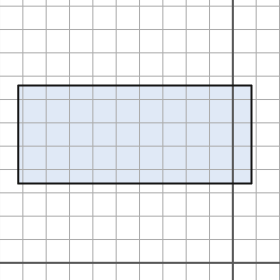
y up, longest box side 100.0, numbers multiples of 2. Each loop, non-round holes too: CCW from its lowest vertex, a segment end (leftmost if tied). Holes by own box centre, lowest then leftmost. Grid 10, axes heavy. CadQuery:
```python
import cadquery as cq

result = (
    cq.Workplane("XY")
    .moveTo(-92.0, 34.0)
    .lineTo(8.0, 34.0)
    .lineTo(8.0, 76.0)
    .lineTo(-92.0, 76.0)
    .close()
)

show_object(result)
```